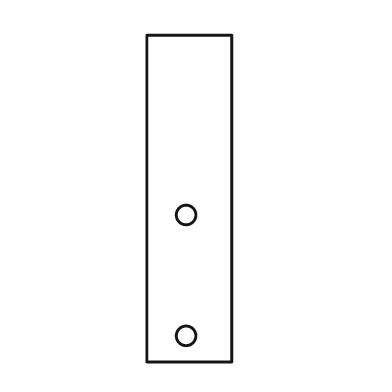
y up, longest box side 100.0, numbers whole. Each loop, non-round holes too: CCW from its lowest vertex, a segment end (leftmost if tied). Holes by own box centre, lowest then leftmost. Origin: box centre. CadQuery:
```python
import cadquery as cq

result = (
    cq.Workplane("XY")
    .moveTo(-13.0, -50.0)
    .lineTo(13.0, -50.0)
    .lineTo(13.0, 50.0)
    .lineTo(-13.0, 50.0)
    .close()
    .moveTo(-1.0, -42.0)
    .circle(3.0)
    .moveTo(-1.0, -5.0)
    .circle(3.0)
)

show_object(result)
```